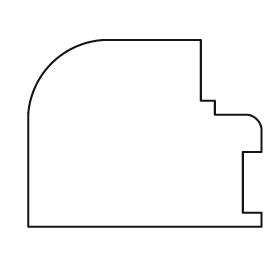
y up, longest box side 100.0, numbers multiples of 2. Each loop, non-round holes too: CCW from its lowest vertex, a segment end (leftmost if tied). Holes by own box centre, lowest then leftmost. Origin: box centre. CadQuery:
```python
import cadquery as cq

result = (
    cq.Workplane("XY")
    .moveTo(-50.0, -40.0)
    .lineTo(50.0, -40.0)
    .lineTo(50.0, -34.0)
    .lineTo(42.0, -34.0)
    .lineTo(42.0, -8.0)
    .lineTo(50.0, -8.0)
    .lineTo(50.0, 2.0)
    .threePointArc((48.0, 6.0), (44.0, 8.0))
    .lineTo(30.0, 8.0)
    .lineTo(30.0, 14.0)
    .lineTo(24.0, 14.0)
    .lineTo(24.0, 40.0)
    .lineTo(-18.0, 40.0)
    .threePointArc((-40.0, 30.0), (-50.0, 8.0))
    .close()
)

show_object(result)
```